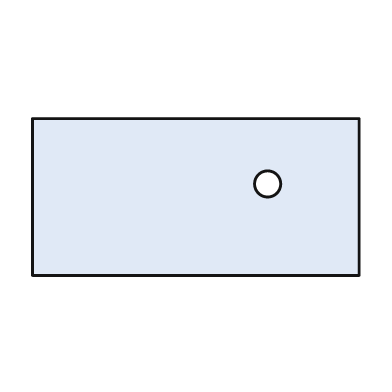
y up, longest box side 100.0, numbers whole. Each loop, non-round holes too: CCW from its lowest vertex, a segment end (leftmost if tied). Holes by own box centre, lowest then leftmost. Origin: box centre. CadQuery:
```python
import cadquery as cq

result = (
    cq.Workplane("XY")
    .moveTo(-50.0, -24.0)
    .lineTo(50.0, -24.0)
    .lineTo(50.0, 24.0)
    .lineTo(-50.0, 24.0)
    .close()
    .moveTo(22.0, 4.0)
    .circle(4.0)
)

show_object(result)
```